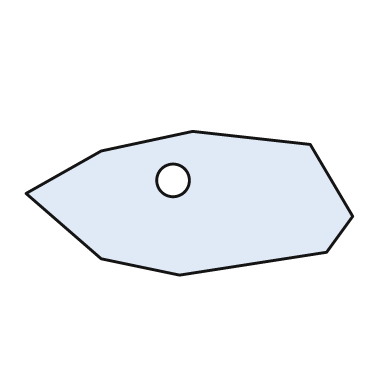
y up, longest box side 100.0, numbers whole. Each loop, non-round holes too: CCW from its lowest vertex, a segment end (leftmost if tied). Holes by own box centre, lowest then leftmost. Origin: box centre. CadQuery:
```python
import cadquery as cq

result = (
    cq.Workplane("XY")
    .moveTo(-3.0, -22.0)
    .lineTo(42.0, -15.0)
    .lineTo(50.0, -4.0)
    .lineTo(37.0, 18.0)
    .lineTo(1.0, 22.0)
    .lineTo(-27.0, 16.0)
    .lineTo(-50.0, 3.0)
    .lineTo(-27.0, -17.0)
    .close()
    .moveTo(-5.0, 7.0)
    .circle(5.0)
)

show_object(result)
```